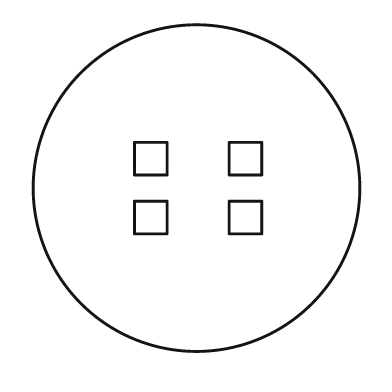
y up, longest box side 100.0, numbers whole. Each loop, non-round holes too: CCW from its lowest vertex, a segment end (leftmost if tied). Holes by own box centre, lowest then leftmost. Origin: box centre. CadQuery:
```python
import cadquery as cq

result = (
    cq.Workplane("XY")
    .moveTo(0.0, 0.0)
    .circle(50.0)
    .moveTo(-19.0, -14.0)
    .lineTo(-9.0, -14.0)
    .lineTo(-9.0, -4.0)
    .lineTo(-19.0, -4.0)
    .close()
    .moveTo(10.0, -14.0)
    .lineTo(20.0, -14.0)
    .lineTo(20.0, -4.0)
    .lineTo(10.0, -4.0)
    .close()
    .moveTo(-19.0, 4.0)
    .lineTo(-9.0, 4.0)
    .lineTo(-9.0, 14.0)
    .lineTo(-19.0, 14.0)
    .close()
    .moveTo(10.0, 4.0)
    .lineTo(20.0, 4.0)
    .lineTo(20.0, 14.0)
    .lineTo(10.0, 14.0)
    .close()
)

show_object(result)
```